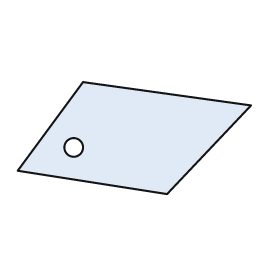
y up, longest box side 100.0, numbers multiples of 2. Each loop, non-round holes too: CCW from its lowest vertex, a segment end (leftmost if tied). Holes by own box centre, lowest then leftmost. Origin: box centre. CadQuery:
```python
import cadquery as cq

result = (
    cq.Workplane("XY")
    .moveTo(14.0, -24.0)
    .lineTo(50.0, 14.0)
    .lineTo(-22.0, 24.0)
    .lineTo(-50.0, -14.0)
    .close()
    .moveTo(-26.0, -4.0)
    .circle(4.0)
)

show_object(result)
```